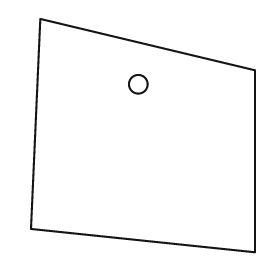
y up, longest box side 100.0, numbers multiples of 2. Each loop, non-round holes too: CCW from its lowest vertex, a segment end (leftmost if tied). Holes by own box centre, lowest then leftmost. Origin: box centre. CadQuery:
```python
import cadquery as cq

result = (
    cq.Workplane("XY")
    .moveTo(48.0, -50.0)
    .lineTo(48.0, 28.0)
    .lineTo(-44.0, 50.0)
    .lineTo(-48.0, -40.0)
    .close()
    .moveTo(-2.0, 22.0)
    .circle(4.0)
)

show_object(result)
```